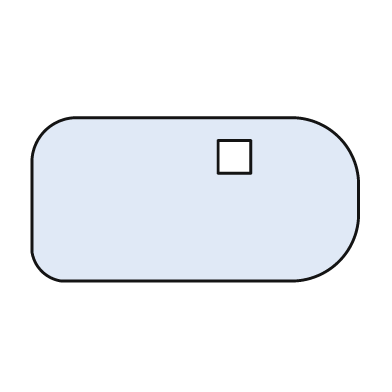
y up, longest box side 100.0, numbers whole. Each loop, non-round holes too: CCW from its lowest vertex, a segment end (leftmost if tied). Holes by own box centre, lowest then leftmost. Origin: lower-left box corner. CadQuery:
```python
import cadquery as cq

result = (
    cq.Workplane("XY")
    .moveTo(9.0, 0.0)
    .lineTo(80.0, 0.0)
    .threePointArc((94.0, 6.0), (100.0, 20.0))
    .lineTo(100.0, 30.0)
    .threePointArc((94.0, 44.0), (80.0, 50.0))
    .lineTo(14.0, 50.0)
    .threePointArc((4.0, 46.0), (0.0, 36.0))
    .lineTo(0.0, 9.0)
    .threePointArc((3.0, 3.0), (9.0, 0.0))
    .close()
    .moveTo(57.0, 33.0)
    .lineTo(67.0, 33.0)
    .lineTo(67.0, 43.0)
    .lineTo(57.0, 43.0)
    .close()
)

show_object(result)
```